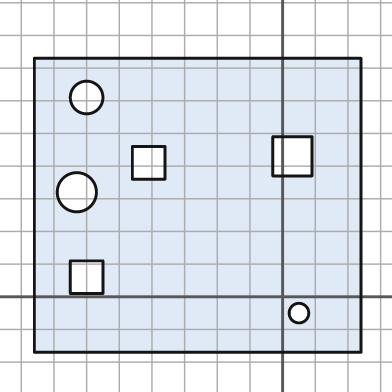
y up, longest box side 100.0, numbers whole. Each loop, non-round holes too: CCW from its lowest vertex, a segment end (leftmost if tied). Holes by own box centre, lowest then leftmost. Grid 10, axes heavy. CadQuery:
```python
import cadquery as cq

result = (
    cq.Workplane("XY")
    .moveTo(-76.0, -17.0)
    .lineTo(24.0, -17.0)
    .lineTo(24.0, 73.0)
    .lineTo(-76.0, 73.0)
    .close()
    .moveTo(5.0, -5.0)
    .circle(3.0)
    .moveTo(-65.0, 1.0)
    .lineTo(-55.0, 1.0)
    .lineTo(-55.0, 11.0)
    .lineTo(-65.0, 11.0)
    .close()
    .moveTo(-63.0, 32.0)
    .circle(6.0)
    .moveTo(-46.0, 36.0)
    .lineTo(-36.0, 36.0)
    .lineTo(-36.0, 46.0)
    .lineTo(-46.0, 46.0)
    .close()
    .moveTo(-3.0, 37.0)
    .lineTo(9.0, 37.0)
    .lineTo(9.0, 49.0)
    .lineTo(-3.0, 49.0)
    .close()
    .moveTo(-60.0, 61.0)
    .circle(5.0)
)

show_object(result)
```